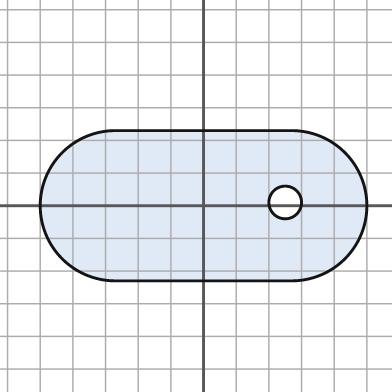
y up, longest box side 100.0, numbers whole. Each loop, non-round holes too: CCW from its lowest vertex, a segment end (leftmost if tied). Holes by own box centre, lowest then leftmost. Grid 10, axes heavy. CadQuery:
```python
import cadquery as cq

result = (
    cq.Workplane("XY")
    .moveTo(-27.0, -23.0)
    .lineTo(27.0, -23.0)
    .threePointArc((50.0, 0.0), (27.0, 23.0))
    .lineTo(-27.0, 23.0)
    .threePointArc((-50.0, 0.0), (-27.0, -23.0))
    .close()
    .moveTo(25.0, 1.0)
    .circle(5.0)
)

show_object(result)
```